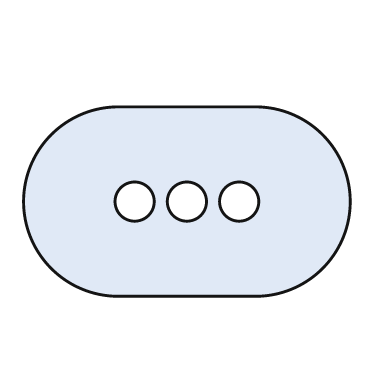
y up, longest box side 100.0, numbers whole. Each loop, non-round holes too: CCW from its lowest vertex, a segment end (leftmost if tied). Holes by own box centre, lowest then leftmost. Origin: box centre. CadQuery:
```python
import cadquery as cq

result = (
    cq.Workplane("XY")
    .moveTo(-21.0, -29.0)
    .lineTo(21.0, -29.0)
    .threePointArc((50.0, 0.0), (21.0, 29.0))
    .lineTo(-21.0, 29.0)
    .threePointArc((-50.0, 0.0), (-21.0, -29.0))
    .close()
    .moveTo(-16.0, 0.0)
    .circle(6.0)
    .moveTo(0.0, 0.0)
    .circle(6.0)
    .moveTo(16.0, 0.0)
    .circle(6.0)
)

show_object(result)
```